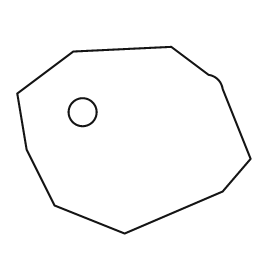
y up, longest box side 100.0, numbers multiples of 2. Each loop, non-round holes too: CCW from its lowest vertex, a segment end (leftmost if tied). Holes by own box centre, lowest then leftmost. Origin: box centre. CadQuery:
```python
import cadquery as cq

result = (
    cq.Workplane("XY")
    .moveTo(-4.0, -40.0)
    .lineTo(38.0, -22.0)
    .lineTo(50.0, -8.0)
    .lineTo(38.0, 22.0)
    .threePointArc((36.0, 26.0), (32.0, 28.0))
    .lineTo(16.0, 40.0)
    .lineTo(-26.0, 38.0)
    .lineTo(-50.0, 20.0)
    .lineTo(-46.0, -4.0)
    .lineTo(-34.0, -28.0)
    .close()
    .moveTo(-22.0, 12.0)
    .circle(6.0)
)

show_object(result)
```